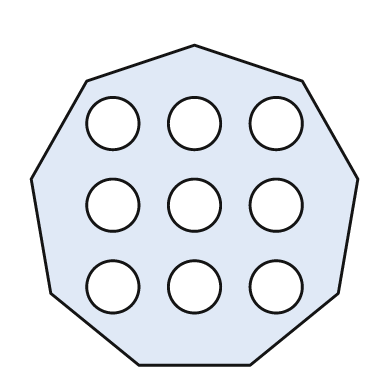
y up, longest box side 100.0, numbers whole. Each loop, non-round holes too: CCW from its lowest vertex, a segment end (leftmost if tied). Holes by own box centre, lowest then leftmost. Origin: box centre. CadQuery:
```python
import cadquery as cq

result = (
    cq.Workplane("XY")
    .moveTo(-17.0, -49.0)
    .lineTo(17.0, -49.0)
    .lineTo(44.0, -27.0)
    .lineTo(50.0, 8.0)
    .lineTo(33.0, 38.0)
    .lineTo(0.0, 49.0)
    .lineTo(-33.0, 38.0)
    .lineTo(-50.0, 8.0)
    .lineTo(-44.0, -27.0)
    .close()
    .moveTo(-25.0, -25.0)
    .circle(8.0)
    .moveTo(0.0, -25.0)
    .circle(8.0)
    .moveTo(25.0, -25.0)
    .circle(8.0)
    .moveTo(-25.0, 0.0)
    .circle(8.0)
    .moveTo(0.0, 0.0)
    .circle(8.0)
    .moveTo(25.0, 0.0)
    .circle(8.0)
    .moveTo(-25.0, 25.0)
    .circle(8.0)
    .moveTo(0.0, 25.0)
    .circle(8.0)
    .moveTo(25.0, 25.0)
    .circle(8.0)
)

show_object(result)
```